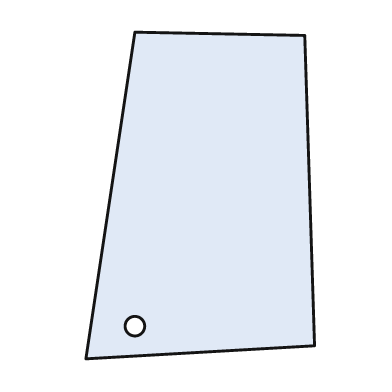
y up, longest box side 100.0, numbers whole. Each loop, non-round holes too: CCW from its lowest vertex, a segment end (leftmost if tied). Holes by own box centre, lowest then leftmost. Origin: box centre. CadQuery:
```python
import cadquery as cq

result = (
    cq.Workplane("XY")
    .moveTo(-35.0, -50.0)
    .lineTo(35.0, -46.0)
    .lineTo(32.0, 49.0)
    .lineTo(-20.0, 50.0)
    .close()
    .moveTo(-20.0, -40.0)
    .circle(3.0)
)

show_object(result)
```